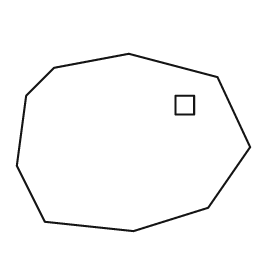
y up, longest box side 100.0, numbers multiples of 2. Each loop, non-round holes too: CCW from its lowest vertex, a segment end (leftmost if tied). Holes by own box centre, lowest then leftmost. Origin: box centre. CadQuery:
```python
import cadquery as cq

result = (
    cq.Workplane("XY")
    .moveTo(0.0, -38.0)
    .lineTo(32.0, -28.0)
    .lineTo(50.0, -2.0)
    .lineTo(36.0, 28.0)
    .lineTo(-2.0, 38.0)
    .lineTo(-34.0, 32.0)
    .lineTo(-46.0, 20.0)
    .lineTo(-50.0, -10.0)
    .lineTo(-38.0, -34.0)
    .close()
    .moveTo(18.0, 12.0)
    .lineTo(26.0, 12.0)
    .lineTo(26.0, 20.0)
    .lineTo(18.0, 20.0)
    .close()
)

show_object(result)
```